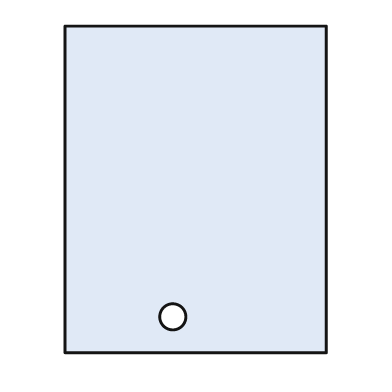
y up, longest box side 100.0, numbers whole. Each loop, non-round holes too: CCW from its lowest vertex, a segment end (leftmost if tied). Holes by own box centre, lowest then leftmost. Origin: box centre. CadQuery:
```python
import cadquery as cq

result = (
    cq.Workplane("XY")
    .moveTo(-40.0, -50.0)
    .lineTo(40.0, -50.0)
    .lineTo(40.0, 50.0)
    .lineTo(-40.0, 50.0)
    .close()
    .moveTo(-7.0, -39.0)
    .circle(4.0)
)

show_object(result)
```